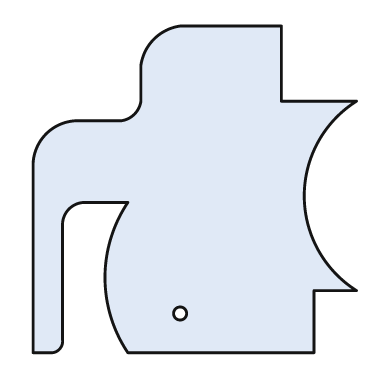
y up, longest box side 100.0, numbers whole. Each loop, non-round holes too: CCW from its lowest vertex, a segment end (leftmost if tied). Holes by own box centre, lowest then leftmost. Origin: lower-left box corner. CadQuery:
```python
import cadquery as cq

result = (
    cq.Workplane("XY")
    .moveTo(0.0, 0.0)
    .lineTo(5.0, 0.0)
    .threePointArc((8.0, 1.0), (9.0, 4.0))
    .lineTo(9.0, 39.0)
    .threePointArc((11.0, 44.0), (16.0, 46.0))
    .lineTo(29.0, 46.0)
    .threePointArc((22.0, 23.0), (29.0, 0.0))
    .lineTo(86.0, 0.0)
    .lineTo(86.0, 19.0)
    .lineTo(99.0, 19.0)
    .threePointArc((83.0, 48.0), (99.0, 77.0))
    .lineTo(76.0, 77.0)
    .lineTo(76.0, 100.0)
    .lineTo(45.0, 100.0)
    .threePointArc((37.0, 96.0), (33.0, 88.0))
    .lineTo(33.0, 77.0)
    .threePointArc((31.0, 73.0), (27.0, 71.0))
    .lineTo(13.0, 71.0)
    .threePointArc((4.0, 67.0), (0.0, 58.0))
    .close()
    .moveTo(45.0, 12.0)
    .circle(2.0)
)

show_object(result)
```